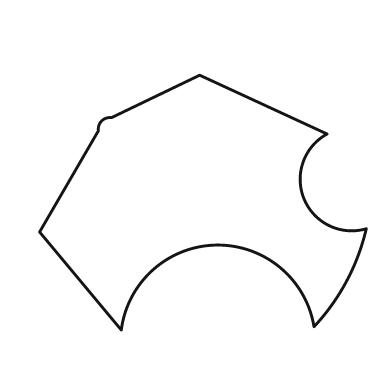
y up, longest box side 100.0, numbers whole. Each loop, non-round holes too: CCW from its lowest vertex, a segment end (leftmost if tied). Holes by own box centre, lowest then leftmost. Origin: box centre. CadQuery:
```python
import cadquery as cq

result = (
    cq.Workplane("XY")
    .moveTo(-25.0, -39.0)
    .threePointArc((4.0, -13.0), (34.0, -38.0))
    .threePointArc((44.0, -24.0), (50.0, -8.0))
    .threePointArc((31.0, 1.0), (38.0, 21.0))
    .lineTo(-1.0, 39.0)
    .lineTo(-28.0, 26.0)
    .threePointArc((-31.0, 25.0), (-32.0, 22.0))
    .lineTo(-50.0, -9.0)
    .close()
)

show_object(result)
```